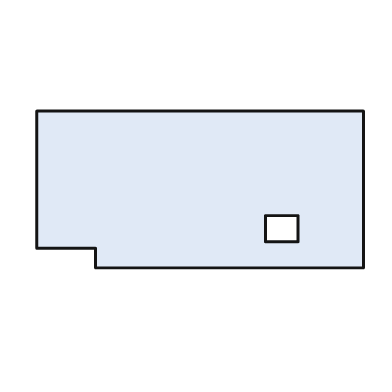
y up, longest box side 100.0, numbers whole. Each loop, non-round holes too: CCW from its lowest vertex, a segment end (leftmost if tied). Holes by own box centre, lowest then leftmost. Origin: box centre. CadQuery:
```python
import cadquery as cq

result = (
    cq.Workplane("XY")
    .moveTo(-32.0, -24.0)
    .lineTo(50.0, -24.0)
    .lineTo(50.0, 24.0)
    .lineTo(-50.0, 24.0)
    .lineTo(-50.0, -18.0)
    .lineTo(-32.0, -18.0)
    .close()
    .moveTo(20.0, -16.0)
    .lineTo(30.0, -16.0)
    .lineTo(30.0, -8.0)
    .lineTo(20.0, -8.0)
    .close()
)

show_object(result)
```